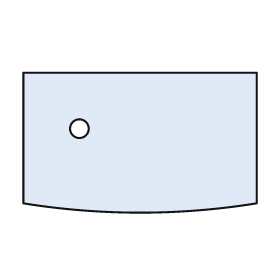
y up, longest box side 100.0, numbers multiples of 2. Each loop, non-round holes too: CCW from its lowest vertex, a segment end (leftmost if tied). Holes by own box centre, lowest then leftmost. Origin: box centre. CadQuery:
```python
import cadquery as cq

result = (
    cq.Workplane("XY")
    .moveTo(-50.0, -26.0)
    .threePointArc((0.0, -30.0), (50.0, -26.0))
    .lineTo(50.0, 30.0)
    .lineTo(-50.0, 30.0)
    .close()
    .moveTo(-26.0, 6.0)
    .circle(4.0)
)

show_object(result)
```